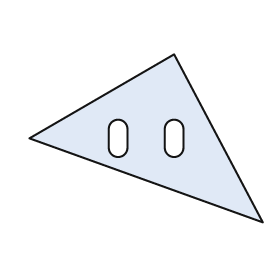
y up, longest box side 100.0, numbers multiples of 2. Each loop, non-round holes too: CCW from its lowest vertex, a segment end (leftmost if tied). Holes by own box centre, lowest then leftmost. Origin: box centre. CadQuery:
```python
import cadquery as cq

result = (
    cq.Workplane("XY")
    .moveTo(50.0, -36.0)
    .lineTo(12.0, 36.0)
    .lineTo(-50.0, 0.0)
    .close()
    .moveTo(-16.0, -4.0)
    .threePointArc((-12.0, -8.0), (-8.0, -4.0))
    .lineTo(-8.0, 4.0)
    .threePointArc((-12.0, 8.0), (-16.0, 4.0))
    .close()
    .moveTo(8.0, -4.0)
    .threePointArc((12.0, -8.0), (16.0, -4.0))
    .lineTo(16.0, 4.0)
    .threePointArc((12.0, 8.0), (8.0, 4.0))
    .close()
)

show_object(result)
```